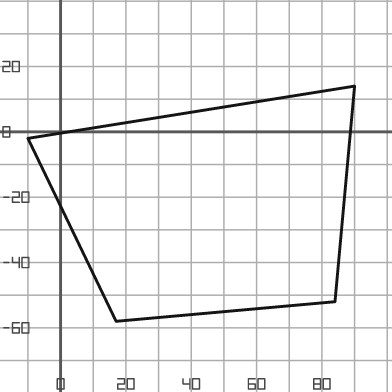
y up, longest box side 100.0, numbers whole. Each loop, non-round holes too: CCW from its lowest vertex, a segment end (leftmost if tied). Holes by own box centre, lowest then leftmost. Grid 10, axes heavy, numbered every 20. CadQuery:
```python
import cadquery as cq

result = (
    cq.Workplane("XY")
    .moveTo(17.0, -58.0)
    .lineTo(84.0, -52.0)
    .lineTo(90.0, 14.0)
    .lineTo(-10.0, -2.0)
    .close()
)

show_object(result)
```